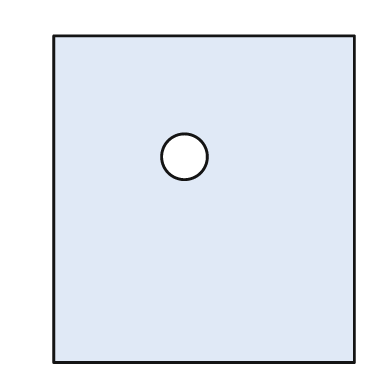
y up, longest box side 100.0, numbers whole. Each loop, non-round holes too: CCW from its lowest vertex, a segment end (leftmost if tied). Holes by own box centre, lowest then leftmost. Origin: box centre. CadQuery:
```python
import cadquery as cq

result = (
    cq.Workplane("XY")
    .moveTo(-46.0, -50.0)
    .lineTo(46.0, -50.0)
    .lineTo(46.0, 50.0)
    .lineTo(-46.0, 50.0)
    .close()
    .moveTo(-6.0, 13.0)
    .circle(7.0)
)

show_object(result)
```